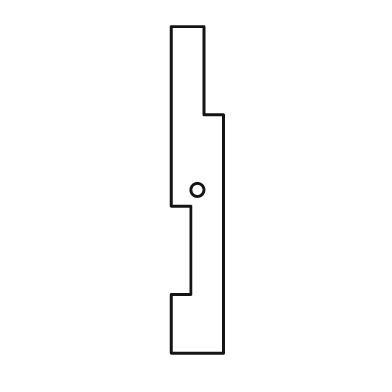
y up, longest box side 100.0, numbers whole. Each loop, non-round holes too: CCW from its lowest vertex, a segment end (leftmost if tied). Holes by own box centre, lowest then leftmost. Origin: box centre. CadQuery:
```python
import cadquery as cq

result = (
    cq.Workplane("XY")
    .moveTo(-8.0, -50.0)
    .lineTo(8.0, -50.0)
    .lineTo(8.0, 23.0)
    .lineTo(2.0, 23.0)
    .lineTo(2.0, 50.0)
    .lineTo(-8.0, 50.0)
    .lineTo(-8.0, -5.0)
    .lineTo(-2.0, -5.0)
    .lineTo(-2.0, -32.0)
    .lineTo(-8.0, -32.0)
    .close()
    .moveTo(0.0, 0.0)
    .circle(2.0)
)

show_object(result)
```